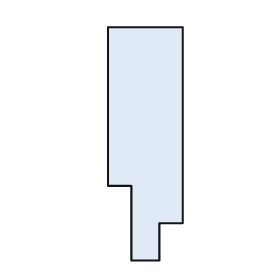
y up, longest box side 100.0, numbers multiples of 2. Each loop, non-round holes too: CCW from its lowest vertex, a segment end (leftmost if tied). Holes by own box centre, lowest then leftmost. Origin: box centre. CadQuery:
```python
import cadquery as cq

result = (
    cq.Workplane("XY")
    .moveTo(-6.0, -50.0)
    .lineTo(6.0, -50.0)
    .lineTo(6.0, -34.0)
    .lineTo(16.0, -34.0)
    .lineTo(16.0, 50.0)
    .lineTo(-16.0, 50.0)
    .lineTo(-16.0, -18.0)
    .lineTo(-6.0, -18.0)
    .close()
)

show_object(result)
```